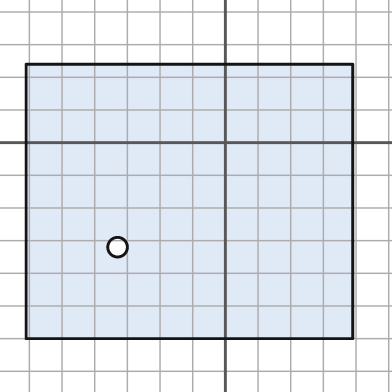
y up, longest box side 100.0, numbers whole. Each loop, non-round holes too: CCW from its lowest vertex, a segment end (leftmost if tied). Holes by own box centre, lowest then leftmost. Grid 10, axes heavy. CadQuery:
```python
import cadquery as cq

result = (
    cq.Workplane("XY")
    .moveTo(-61.0, -60.0)
    .lineTo(39.0, -60.0)
    .lineTo(39.0, 24.0)
    .lineTo(-61.0, 24.0)
    .close()
    .moveTo(-33.0, -32.0)
    .circle(3.0)
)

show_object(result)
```